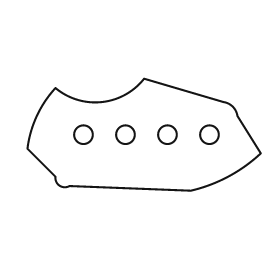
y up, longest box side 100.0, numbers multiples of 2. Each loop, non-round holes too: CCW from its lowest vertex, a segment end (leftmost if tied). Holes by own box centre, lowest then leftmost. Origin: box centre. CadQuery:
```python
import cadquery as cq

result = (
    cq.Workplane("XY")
    .moveTo(20.0, -24.0)
    .threePointArc((36.0, -18.0), (50.0, -8.0))
    .lineTo(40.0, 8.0)
    .threePointArc((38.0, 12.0), (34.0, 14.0))
    .lineTo(0.0, 24.0)
    .threePointArc((-18.0, 14.0), (-38.0, 20.0))
    .threePointArc((-46.0, 8.0), (-50.0, -6.0))
    .lineTo(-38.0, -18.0)
    .threePointArc((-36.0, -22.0), (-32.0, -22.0))
    .close()
    .moveTo(-26.0, 0.0)
    .circle(4.0)
    .moveTo(-8.0, 0.0)
    .circle(4.0)
    .moveTo(10.0, 0.0)
    .circle(4.0)
    .moveTo(28.0, 0.0)
    .circle(4.0)
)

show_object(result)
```